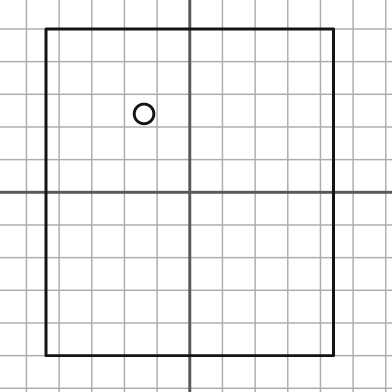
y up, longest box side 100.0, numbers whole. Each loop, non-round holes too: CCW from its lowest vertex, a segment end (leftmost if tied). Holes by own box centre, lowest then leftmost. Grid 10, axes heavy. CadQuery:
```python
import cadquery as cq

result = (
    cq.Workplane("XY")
    .moveTo(-44.0, -50.0)
    .lineTo(44.0, -50.0)
    .lineTo(44.0, 50.0)
    .lineTo(-44.0, 50.0)
    .close()
    .moveTo(-14.0, 24.0)
    .circle(3.0)
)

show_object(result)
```